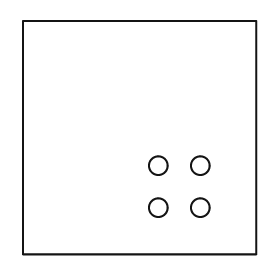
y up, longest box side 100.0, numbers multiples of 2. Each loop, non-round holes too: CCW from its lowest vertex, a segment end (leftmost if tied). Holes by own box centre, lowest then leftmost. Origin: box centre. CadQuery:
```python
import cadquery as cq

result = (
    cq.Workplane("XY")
    .moveTo(-50.0, -50.0)
    .lineTo(50.0, -50.0)
    .lineTo(50.0, 50.0)
    .lineTo(-50.0, 50.0)
    .close()
    .moveTo(8.0, -30.0)
    .circle(4.0)
    .moveTo(26.0, -30.0)
    .circle(4.0)
    .moveTo(8.0, -12.0)
    .circle(4.0)
    .moveTo(26.0, -12.0)
    .circle(4.0)
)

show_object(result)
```